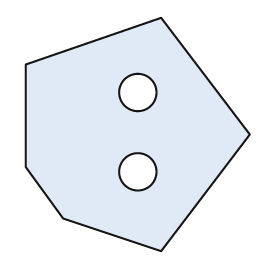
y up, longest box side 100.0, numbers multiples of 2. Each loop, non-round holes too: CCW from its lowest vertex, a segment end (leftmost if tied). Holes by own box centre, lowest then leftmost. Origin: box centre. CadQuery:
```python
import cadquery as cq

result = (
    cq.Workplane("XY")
    .moveTo(10.0, -50.0)
    .lineTo(48.0, 0.0)
    .lineTo(10.0, 50.0)
    .lineTo(-48.0, 30.0)
    .lineTo(-48.0, -14.0)
    .lineTo(-32.0, -36.0)
    .close()
    .moveTo(0.0, -16.0)
    .circle(8.0)
    .moveTo(0.0, 18.0)
    .circle(8.0)
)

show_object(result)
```